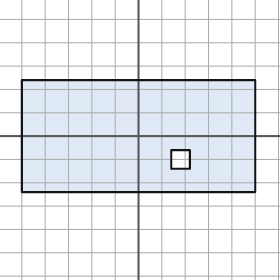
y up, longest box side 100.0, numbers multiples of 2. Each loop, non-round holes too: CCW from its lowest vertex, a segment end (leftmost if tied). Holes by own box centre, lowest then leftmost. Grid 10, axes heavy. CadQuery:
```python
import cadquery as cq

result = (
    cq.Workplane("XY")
    .moveTo(-50.0, -24.0)
    .lineTo(50.0, -24.0)
    .lineTo(50.0, 24.0)
    .lineTo(-50.0, 24.0)
    .close()
    .moveTo(14.0, -14.0)
    .lineTo(22.0, -14.0)
    .lineTo(22.0, -6.0)
    .lineTo(14.0, -6.0)
    .close()
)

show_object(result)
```